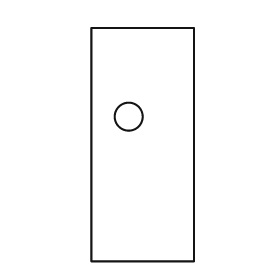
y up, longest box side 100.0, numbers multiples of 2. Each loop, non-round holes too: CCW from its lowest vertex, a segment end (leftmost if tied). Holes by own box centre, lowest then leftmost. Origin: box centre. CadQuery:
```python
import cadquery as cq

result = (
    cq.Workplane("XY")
    .moveTo(-22.0, -50.0)
    .lineTo(22.0, -50.0)
    .lineTo(22.0, 50.0)
    .lineTo(-22.0, 50.0)
    .close()
    .moveTo(-6.0, 12.0)
    .circle(6.0)
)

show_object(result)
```